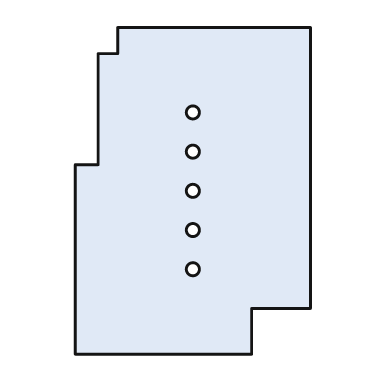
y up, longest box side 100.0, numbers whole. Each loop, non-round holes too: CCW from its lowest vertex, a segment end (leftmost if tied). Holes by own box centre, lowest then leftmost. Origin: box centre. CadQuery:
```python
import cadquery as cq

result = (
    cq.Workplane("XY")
    .moveTo(-36.0, -50.0)
    .lineTo(18.0, -50.0)
    .lineTo(18.0, -36.0)
    .lineTo(36.0, -36.0)
    .lineTo(36.0, 50.0)
    .lineTo(-23.0, 50.0)
    .lineTo(-23.0, 42.0)
    .lineTo(-29.0, 42.0)
    .lineTo(-29.0, 8.0)
    .lineTo(-36.0, 8.0)
    .close()
    .moveTo(0.0, -24.0)
    .circle(2.0)
    .moveTo(0.0, -12.0)
    .circle(2.0)
    .moveTo(0.0, 0.0)
    .circle(2.0)
    .moveTo(0.0, 12.0)
    .circle(2.0)
    .moveTo(0.0, 24.0)
    .circle(2.0)
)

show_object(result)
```